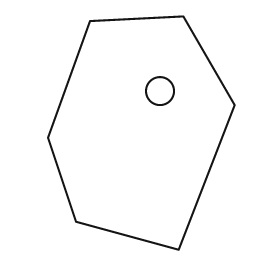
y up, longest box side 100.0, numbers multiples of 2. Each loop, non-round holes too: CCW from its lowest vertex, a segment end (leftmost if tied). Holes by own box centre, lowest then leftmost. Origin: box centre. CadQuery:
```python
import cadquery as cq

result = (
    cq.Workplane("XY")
    .moveTo(16.0, -50.0)
    .lineTo(40.0, 12.0)
    .lineTo(18.0, 50.0)
    .lineTo(-22.0, 48.0)
    .lineTo(-40.0, -2.0)
    .lineTo(-28.0, -38.0)
    .close()
    .moveTo(8.0, 18.0)
    .circle(6.0)
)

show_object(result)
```